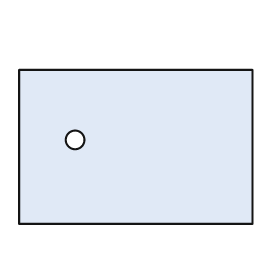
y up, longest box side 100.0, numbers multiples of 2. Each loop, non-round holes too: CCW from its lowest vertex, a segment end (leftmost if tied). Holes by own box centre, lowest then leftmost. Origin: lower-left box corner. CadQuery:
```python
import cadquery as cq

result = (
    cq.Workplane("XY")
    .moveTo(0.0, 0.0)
    .lineTo(100.0, 0.0)
    .lineTo(100.0, 66.0)
    .lineTo(0.0, 66.0)
    .close()
    .moveTo(24.0, 36.0)
    .circle(4.0)
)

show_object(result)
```